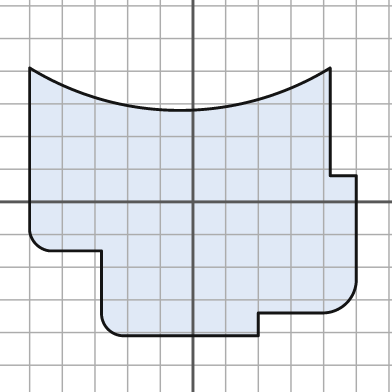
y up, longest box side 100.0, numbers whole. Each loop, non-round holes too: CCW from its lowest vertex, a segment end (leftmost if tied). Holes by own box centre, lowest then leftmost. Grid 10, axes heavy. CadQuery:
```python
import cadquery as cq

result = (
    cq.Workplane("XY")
    .moveTo(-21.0, -41.0)
    .lineTo(20.0, -41.0)
    .lineTo(20.0, -34.0)
    .lineTo(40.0, -34.0)
    .threePointArc((47.0, -31.0), (50.0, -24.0))
    .lineTo(50.0, 8.0)
    .lineTo(42.0, 8.0)
    .lineTo(42.0, 41.0)
    .threePointArc((-4.0, 28.0), (-50.0, 41.0))
    .lineTo(-50.0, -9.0)
    .threePointArc((-48.0, -13.0), (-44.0, -15.0))
    .lineTo(-28.0, -15.0)
    .lineTo(-28.0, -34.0)
    .threePointArc((-26.0, -39.0), (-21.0, -41.0))
    .close()
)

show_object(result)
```